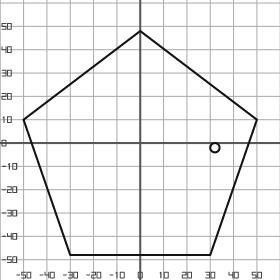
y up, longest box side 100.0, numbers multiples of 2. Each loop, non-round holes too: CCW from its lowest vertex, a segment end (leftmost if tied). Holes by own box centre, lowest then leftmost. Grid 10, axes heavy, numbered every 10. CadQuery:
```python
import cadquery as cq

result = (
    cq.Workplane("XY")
    .moveTo(-30.0, -48.0)
    .lineTo(30.0, -48.0)
    .lineTo(50.0, 10.0)
    .lineTo(0.0, 48.0)
    .lineTo(-50.0, 10.0)
    .close()
    .moveTo(32.0, -2.0)
    .circle(2.0)
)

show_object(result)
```